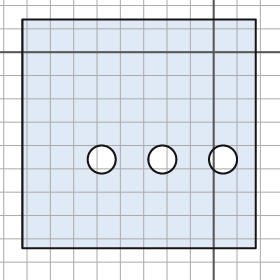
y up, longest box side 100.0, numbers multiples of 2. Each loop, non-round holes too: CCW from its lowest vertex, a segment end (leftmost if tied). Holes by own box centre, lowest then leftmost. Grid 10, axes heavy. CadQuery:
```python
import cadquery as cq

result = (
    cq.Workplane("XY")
    .moveTo(-82.0, -84.0)
    .lineTo(18.0, -84.0)
    .lineTo(18.0, 14.0)
    .lineTo(-82.0, 14.0)
    .close()
    .moveTo(-48.0, -46.0)
    .circle(6.0)
    .moveTo(-22.0, -46.0)
    .circle(6.0)
    .moveTo(4.0, -46.0)
    .circle(6.0)
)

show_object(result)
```